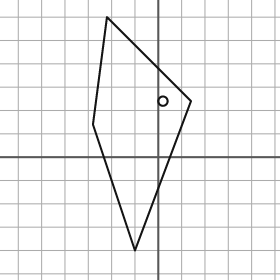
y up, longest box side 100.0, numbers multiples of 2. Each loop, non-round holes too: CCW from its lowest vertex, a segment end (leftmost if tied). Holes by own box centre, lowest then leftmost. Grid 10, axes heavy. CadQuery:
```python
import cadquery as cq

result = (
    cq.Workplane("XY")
    .moveTo(-10.0, -40.0)
    .lineTo(14.0, 24.0)
    .lineTo(-22.0, 60.0)
    .lineTo(-28.0, 14.0)
    .close()
    .moveTo(2.0, 24.0)
    .circle(2.0)
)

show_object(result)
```